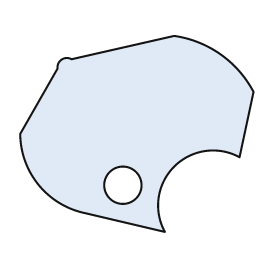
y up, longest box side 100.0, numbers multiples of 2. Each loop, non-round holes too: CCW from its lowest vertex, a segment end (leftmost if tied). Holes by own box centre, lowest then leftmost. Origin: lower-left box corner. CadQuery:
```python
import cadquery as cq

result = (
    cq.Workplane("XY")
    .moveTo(62.0, 0.0)
    .threePointArc((66.0, 28.0), (94.0, 32.0))
    .lineTo(100.0, 60.0)
    .threePointArc((86.0, 76.0), (66.0, 84.0))
    .lineTo(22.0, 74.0)
    .threePointArc((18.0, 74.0), (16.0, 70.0))
    .lineTo(0.0, 42.0)
    .threePointArc((8.0, 20.0), (28.0, 8.0))
    .close()
    .moveTo(44.0, 20.0)
    .circle(8.0)
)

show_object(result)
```